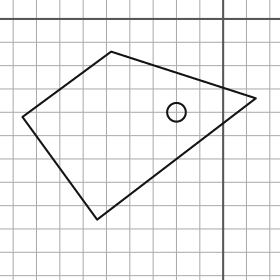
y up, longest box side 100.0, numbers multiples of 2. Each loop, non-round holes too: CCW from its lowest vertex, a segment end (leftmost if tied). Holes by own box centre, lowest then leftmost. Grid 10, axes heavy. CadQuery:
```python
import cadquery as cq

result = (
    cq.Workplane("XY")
    .moveTo(-54.0, -86.0)
    .lineTo(14.0, -34.0)
    .lineTo(-48.0, -14.0)
    .lineTo(-86.0, -42.0)
    .close()
    .moveTo(-20.0, -40.0)
    .circle(4.0)
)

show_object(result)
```